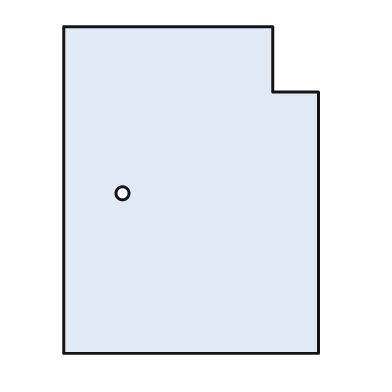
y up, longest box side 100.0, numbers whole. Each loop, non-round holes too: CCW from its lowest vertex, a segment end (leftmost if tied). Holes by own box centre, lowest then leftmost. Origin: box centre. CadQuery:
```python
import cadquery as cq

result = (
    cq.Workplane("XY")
    .moveTo(-39.0, -50.0)
    .lineTo(39.0, -50.0)
    .lineTo(39.0, 30.0)
    .lineTo(25.0, 30.0)
    .lineTo(25.0, 50.0)
    .lineTo(-39.0, 50.0)
    .close()
    .moveTo(-21.0, -1.0)
    .circle(2.0)
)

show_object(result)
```